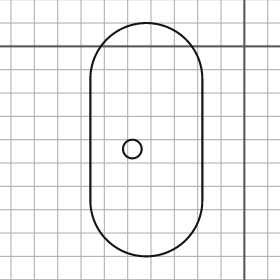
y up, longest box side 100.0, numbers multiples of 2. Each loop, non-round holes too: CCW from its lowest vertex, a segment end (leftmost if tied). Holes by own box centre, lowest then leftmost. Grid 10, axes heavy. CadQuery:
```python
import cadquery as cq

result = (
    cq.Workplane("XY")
    .moveTo(-66.0, -66.0)
    .threePointArc((-42.0, -90.0), (-18.0, -66.0))
    .lineTo(-18.0, -14.0)
    .threePointArc((-42.0, 10.0), (-66.0, -14.0))
    .close()
    .moveTo(-48.0, -44.0)
    .circle(4.0)
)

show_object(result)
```